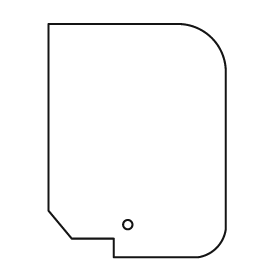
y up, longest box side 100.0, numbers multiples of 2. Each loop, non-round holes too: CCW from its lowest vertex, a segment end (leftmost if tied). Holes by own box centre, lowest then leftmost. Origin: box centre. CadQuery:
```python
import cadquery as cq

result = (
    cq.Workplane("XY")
    .moveTo(-10.0, -50.0)
    .lineTo(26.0, -50.0)
    .threePointArc((34.0, -46.0), (38.0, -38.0))
    .lineTo(38.0, 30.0)
    .threePointArc((32.0, 44.0), (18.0, 50.0))
    .lineTo(-38.0, 50.0)
    .lineTo(-38.0, -30.0)
    .lineTo(-28.0, -42.0)
    .lineTo(-10.0, -42.0)
    .close()
    .moveTo(-4.0, -36.0)
    .circle(2.0)
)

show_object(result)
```